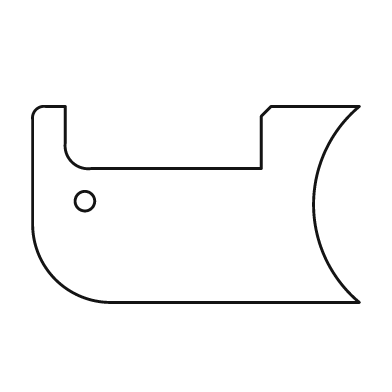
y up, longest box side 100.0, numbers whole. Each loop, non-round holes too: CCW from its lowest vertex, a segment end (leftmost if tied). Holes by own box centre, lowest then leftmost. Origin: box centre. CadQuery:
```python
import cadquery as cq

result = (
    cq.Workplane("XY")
    .moveTo(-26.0, -30.0)
    .lineTo(50.0, -30.0)
    .threePointArc((36.0, 0.0), (50.0, 30.0))
    .lineTo(23.0, 30.0)
    .lineTo(20.0, 27.0)
    .lineTo(20.0, 11.0)
    .lineTo(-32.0, 11.0)
    .threePointArc((-38.0, 13.0), (-40.0, 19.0))
    .lineTo(-40.0, 30.0)
    .lineTo(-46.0, 30.0)
    .threePointArc((-49.0, 29.0), (-50.0, 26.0))
    .lineTo(-50.0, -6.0)
    .threePointArc((-43.0, -23.0), (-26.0, -30.0))
    .close()
    .moveTo(-34.0, 1.0)
    .circle(3.0)
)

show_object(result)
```